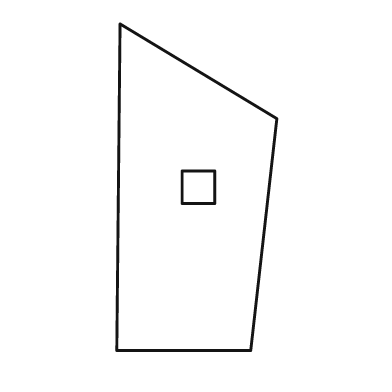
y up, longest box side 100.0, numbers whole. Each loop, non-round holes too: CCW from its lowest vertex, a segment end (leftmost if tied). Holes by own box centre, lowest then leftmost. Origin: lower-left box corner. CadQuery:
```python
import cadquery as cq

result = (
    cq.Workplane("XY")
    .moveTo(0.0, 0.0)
    .lineTo(41.0, 0.0)
    .lineTo(49.0, 71.0)
    .lineTo(1.0, 100.0)
    .close()
    .moveTo(20.0, 45.0)
    .lineTo(30.0, 45.0)
    .lineTo(30.0, 55.0)
    .lineTo(20.0, 55.0)
    .close()
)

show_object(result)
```